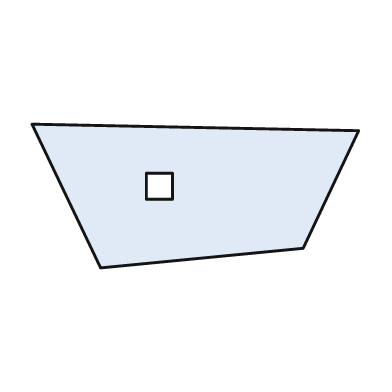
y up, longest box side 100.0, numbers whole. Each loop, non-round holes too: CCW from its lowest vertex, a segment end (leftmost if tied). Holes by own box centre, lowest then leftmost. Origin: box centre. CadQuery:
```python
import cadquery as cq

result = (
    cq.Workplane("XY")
    .moveTo(-29.0, -22.0)
    .lineTo(33.0, -16.0)
    .lineTo(50.0, 20.0)
    .lineTo(-50.0, 22.0)
    .close()
    .moveTo(-15.0, -1.0)
    .lineTo(-7.0, -1.0)
    .lineTo(-7.0, 7.0)
    .lineTo(-15.0, 7.0)
    .close()
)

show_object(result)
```